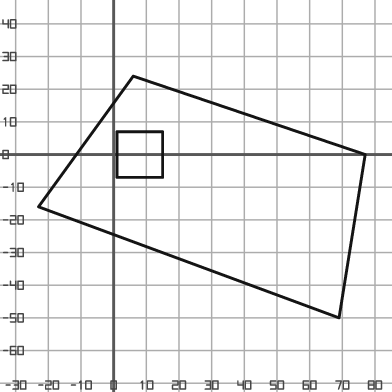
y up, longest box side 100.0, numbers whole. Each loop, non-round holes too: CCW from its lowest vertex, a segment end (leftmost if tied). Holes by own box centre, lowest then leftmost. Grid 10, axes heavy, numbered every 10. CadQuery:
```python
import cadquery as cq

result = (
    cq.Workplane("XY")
    .moveTo(69.0, -50.0)
    .lineTo(77.0, 0.0)
    .lineTo(6.0, 24.0)
    .lineTo(-23.0, -16.0)
    .close()
    .moveTo(1.0, -7.0)
    .lineTo(15.0, -7.0)
    .lineTo(15.0, 7.0)
    .lineTo(1.0, 7.0)
    .close()
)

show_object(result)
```